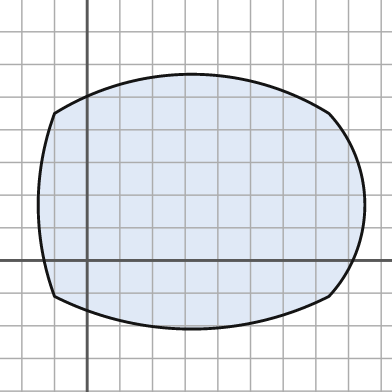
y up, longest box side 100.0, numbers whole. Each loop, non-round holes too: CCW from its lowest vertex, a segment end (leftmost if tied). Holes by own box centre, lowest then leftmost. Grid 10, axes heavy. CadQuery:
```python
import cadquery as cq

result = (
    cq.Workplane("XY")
    .moveTo(-10.0, -11.0)
    .threePointArc((32.0, -21.0), (74.0, -11.0))
    .threePointArc((85.0, 17.0), (74.0, 45.0))
    .threePointArc((32.0, 57.0), (-10.0, 45.0))
    .threePointArc((-15.0, 17.0), (-10.0, -11.0))
    .close()
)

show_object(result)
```